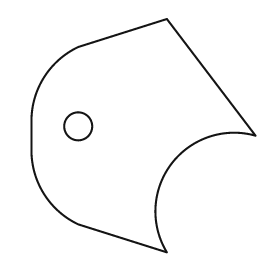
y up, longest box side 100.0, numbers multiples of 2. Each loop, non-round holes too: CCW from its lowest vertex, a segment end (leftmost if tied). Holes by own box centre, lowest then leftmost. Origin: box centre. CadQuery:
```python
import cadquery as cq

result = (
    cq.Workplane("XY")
    .moveTo(10.0, -50.0)
    .threePointArc((12.0, -12.0), (48.0, 0.0))
    .lineTo(10.0, 50.0)
    .lineTo(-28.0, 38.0)
    .threePointArc((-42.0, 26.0), (-48.0, 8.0))
    .lineTo(-48.0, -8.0)
    .threePointArc((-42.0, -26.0), (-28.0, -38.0))
    .close()
    .moveTo(-28.0, 4.0)
    .circle(6.0)
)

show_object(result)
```